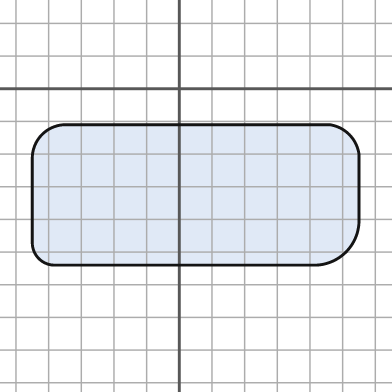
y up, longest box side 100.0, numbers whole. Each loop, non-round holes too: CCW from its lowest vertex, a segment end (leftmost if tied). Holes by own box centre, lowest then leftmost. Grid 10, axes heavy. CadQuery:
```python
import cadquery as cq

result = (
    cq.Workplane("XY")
    .moveTo(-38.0, -54.0)
    .lineTo(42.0, -54.0)
    .threePointArc((51.0, -50.0), (55.0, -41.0))
    .lineTo(55.0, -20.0)
    .threePointArc((52.0, -14.0), (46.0, -11.0))
    .lineTo(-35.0, -11.0)
    .threePointArc((-42.0, -14.0), (-45.0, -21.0))
    .lineTo(-45.0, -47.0)
    .threePointArc((-43.0, -52.0), (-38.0, -54.0))
    .close()
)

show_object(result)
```